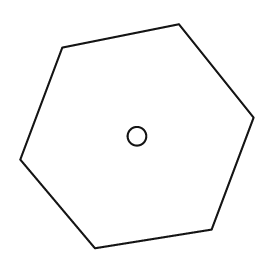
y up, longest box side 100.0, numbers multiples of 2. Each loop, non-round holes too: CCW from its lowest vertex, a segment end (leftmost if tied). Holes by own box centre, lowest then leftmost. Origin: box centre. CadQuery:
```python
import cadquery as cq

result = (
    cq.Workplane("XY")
    .moveTo(-18.0, -48.0)
    .lineTo(32.0, -40.0)
    .lineTo(50.0, 8.0)
    .lineTo(18.0, 48.0)
    .lineTo(-32.0, 38.0)
    .lineTo(-50.0, -10.0)
    .close()
    .moveTo(0.0, 0.0)
    .circle(4.0)
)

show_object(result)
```